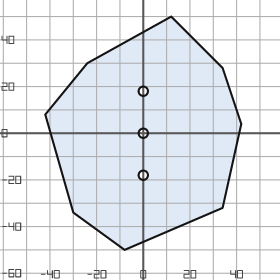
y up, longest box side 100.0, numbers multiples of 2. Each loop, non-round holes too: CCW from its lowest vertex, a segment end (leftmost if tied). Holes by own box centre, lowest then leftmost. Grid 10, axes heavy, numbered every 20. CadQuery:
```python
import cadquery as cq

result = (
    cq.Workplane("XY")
    .moveTo(-8.0, -50.0)
    .lineTo(34.0, -32.0)
    .lineTo(42.0, 4.0)
    .lineTo(34.0, 28.0)
    .lineTo(12.0, 50.0)
    .lineTo(-24.0, 30.0)
    .lineTo(-42.0, 8.0)
    .lineTo(-30.0, -34.0)
    .close()
    .moveTo(0.0, -18.0)
    .circle(2.0)
    .moveTo(0.0, 0.0)
    .circle(2.0)
    .moveTo(0.0, 18.0)
    .circle(2.0)
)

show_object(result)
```